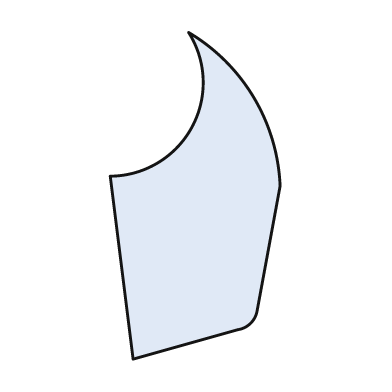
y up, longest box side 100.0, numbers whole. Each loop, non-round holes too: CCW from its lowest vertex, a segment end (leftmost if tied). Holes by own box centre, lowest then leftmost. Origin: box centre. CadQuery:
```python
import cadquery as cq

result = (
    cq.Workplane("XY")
    .moveTo(-19.0, -50.0)
    .lineTo(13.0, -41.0)
    .threePointArc((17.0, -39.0), (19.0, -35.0))
    .lineTo(26.0, 3.0)
    .threePointArc((18.0, 30.0), (-2.0, 50.0))
    .threePointArc((-1.0, 21.0), (-26.0, 6.0))
    .close()
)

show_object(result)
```